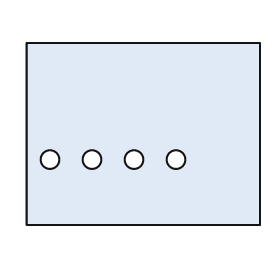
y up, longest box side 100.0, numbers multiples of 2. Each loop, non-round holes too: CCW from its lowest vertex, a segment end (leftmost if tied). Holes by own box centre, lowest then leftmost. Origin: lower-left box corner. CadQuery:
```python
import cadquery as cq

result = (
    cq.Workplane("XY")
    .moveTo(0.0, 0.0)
    .lineTo(100.0, 0.0)
    .lineTo(100.0, 78.0)
    .lineTo(0.0, 78.0)
    .close()
    .moveTo(10.0, 28.0)
    .circle(4.0)
    .moveTo(28.0, 28.0)
    .circle(4.0)
    .moveTo(46.0, 28.0)
    .circle(4.0)
    .moveTo(64.0, 28.0)
    .circle(4.0)
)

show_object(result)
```